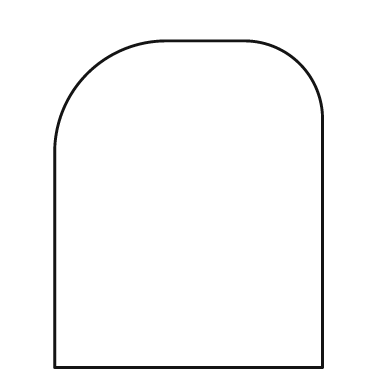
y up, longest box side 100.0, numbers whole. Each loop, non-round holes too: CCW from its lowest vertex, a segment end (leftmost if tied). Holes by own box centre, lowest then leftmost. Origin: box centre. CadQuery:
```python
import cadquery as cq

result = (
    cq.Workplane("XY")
    .moveTo(-41.0, -50.0)
    .lineTo(41.0, -50.0)
    .lineTo(41.0, 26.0)
    .threePointArc((34.0, 43.0), (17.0, 50.0))
    .lineTo(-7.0, 50.0)
    .threePointArc((-31.0, 40.0), (-41.0, 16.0))
    .close()
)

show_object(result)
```